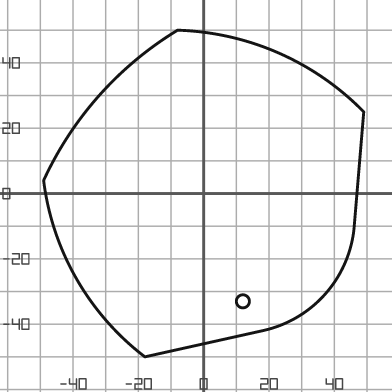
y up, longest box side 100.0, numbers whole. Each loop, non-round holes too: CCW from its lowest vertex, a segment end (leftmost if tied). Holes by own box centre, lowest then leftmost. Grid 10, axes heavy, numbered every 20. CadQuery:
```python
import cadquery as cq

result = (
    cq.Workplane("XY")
    .moveTo(-18.0, -50.0)
    .lineTo(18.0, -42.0)
    .threePointArc((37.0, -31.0), (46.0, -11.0))
    .lineTo(49.0, 25.0)
    .threePointArc((23.0, 43.0), (-8.0, 50.0))
    .threePointArc((-32.0, 30.0), (-49.0, 4.0))
    .threePointArc((-39.0, -26.0), (-18.0, -50.0))
    .close()
    .moveTo(12.0, -33.0)
    .circle(2.0)
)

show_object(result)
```